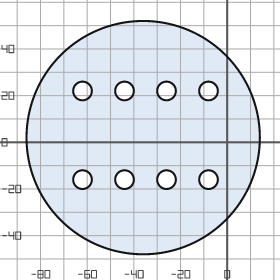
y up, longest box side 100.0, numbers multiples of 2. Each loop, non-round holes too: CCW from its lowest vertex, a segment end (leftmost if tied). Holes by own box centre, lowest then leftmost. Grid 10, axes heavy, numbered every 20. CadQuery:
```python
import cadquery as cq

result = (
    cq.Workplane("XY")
    .moveTo(-36.0, 2.0)
    .circle(50.0)
    .moveTo(-62.0, -16.0)
    .circle(4.0)
    .moveTo(-44.0, -16.0)
    .circle(4.0)
    .moveTo(-26.0, -16.0)
    .circle(4.0)
    .moveTo(-8.0, -16.0)
    .circle(4.0)
    .moveTo(-62.0, 22.0)
    .circle(4.0)
    .moveTo(-44.0, 22.0)
    .circle(4.0)
    .moveTo(-26.0, 22.0)
    .circle(4.0)
    .moveTo(-8.0, 22.0)
    .circle(4.0)
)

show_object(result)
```